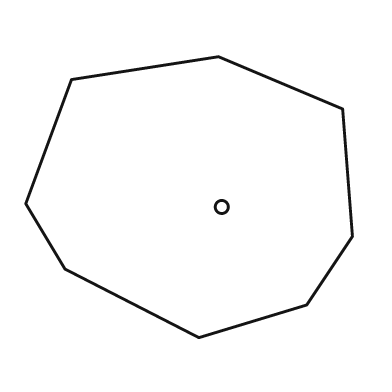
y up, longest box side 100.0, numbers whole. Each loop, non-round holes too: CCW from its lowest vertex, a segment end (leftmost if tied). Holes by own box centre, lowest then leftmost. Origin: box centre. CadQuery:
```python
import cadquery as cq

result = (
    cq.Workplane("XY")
    .moveTo(3.0, -43.0)
    .lineTo(36.0, -33.0)
    .lineTo(50.0, -12.0)
    .lineTo(47.0, 27.0)
    .lineTo(9.0, 43.0)
    .lineTo(-36.0, 36.0)
    .lineTo(-50.0, -2.0)
    .lineTo(-38.0, -22.0)
    .close()
    .moveTo(10.0, -3.0)
    .circle(2.0)
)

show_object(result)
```